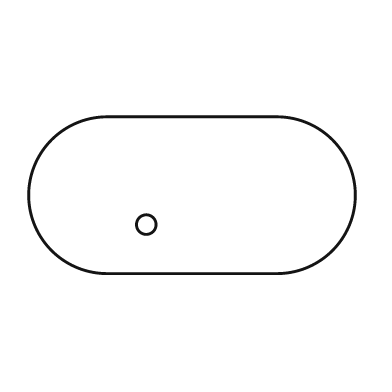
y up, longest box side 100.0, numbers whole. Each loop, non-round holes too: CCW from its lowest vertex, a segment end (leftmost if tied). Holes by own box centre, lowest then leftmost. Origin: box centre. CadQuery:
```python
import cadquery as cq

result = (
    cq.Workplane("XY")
    .moveTo(-26.0, -24.0)
    .lineTo(26.0, -24.0)
    .threePointArc((50.0, 0.0), (26.0, 24.0))
    .lineTo(-26.0, 24.0)
    .threePointArc((-50.0, 0.0), (-26.0, -24.0))
    .close()
    .moveTo(-14.0, -9.0)
    .circle(3.0)
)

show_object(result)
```